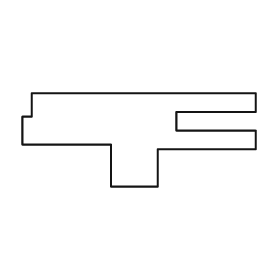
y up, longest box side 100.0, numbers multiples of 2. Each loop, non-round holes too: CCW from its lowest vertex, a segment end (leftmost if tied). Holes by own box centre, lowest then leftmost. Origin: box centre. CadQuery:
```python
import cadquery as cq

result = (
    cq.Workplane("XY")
    .moveTo(-12.0, -20.0)
    .lineTo(8.0, -20.0)
    .lineTo(8.0, -4.0)
    .lineTo(50.0, -4.0)
    .lineTo(50.0, 4.0)
    .lineTo(16.0, 4.0)
    .lineTo(16.0, 12.0)
    .lineTo(50.0, 12.0)
    .lineTo(50.0, 20.0)
    .lineTo(-46.0, 20.0)
    .lineTo(-46.0, 10.0)
    .lineTo(-50.0, 10.0)
    .lineTo(-50.0, -2.0)
    .lineTo(-12.0, -2.0)
    .close()
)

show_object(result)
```